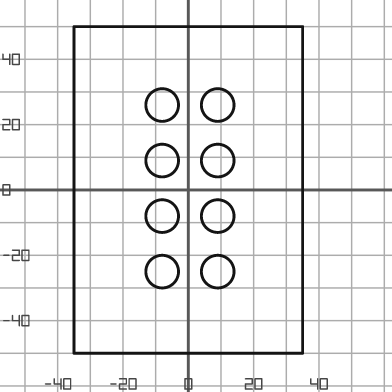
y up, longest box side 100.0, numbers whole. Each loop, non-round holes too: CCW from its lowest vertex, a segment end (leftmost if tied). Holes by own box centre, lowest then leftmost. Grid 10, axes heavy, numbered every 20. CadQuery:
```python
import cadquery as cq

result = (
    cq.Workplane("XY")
    .moveTo(-35.0, -50.0)
    .lineTo(35.0, -50.0)
    .lineTo(35.0, 50.0)
    .lineTo(-35.0, 50.0)
    .close()
    .moveTo(-8.0, -25.0)
    .circle(5.0)
    .moveTo(9.0, -25.0)
    .circle(5.0)
    .moveTo(-8.0, -8.0)
    .circle(5.0)
    .moveTo(9.0, -8.0)
    .circle(5.0)
    .moveTo(-8.0, 9.0)
    .circle(5.0)
    .moveTo(9.0, 9.0)
    .circle(5.0)
    .moveTo(-8.0, 26.0)
    .circle(5.0)
    .moveTo(9.0, 26.0)
    .circle(5.0)
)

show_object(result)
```